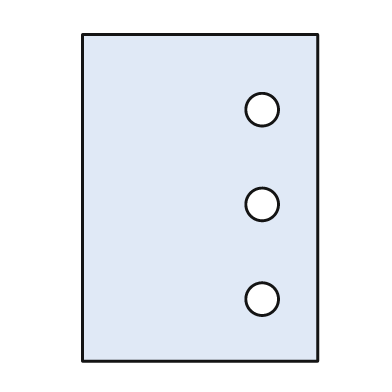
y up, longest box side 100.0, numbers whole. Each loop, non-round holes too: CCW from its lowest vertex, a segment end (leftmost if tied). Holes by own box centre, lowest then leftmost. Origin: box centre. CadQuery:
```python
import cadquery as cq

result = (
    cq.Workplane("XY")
    .moveTo(-36.0, -50.0)
    .lineTo(36.0, -50.0)
    .lineTo(36.0, 50.0)
    .lineTo(-36.0, 50.0)
    .close()
    .moveTo(19.0, -31.0)
    .circle(5.0)
    .moveTo(19.0, -2.0)
    .circle(5.0)
    .moveTo(19.0, 27.0)
    .circle(5.0)
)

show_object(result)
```